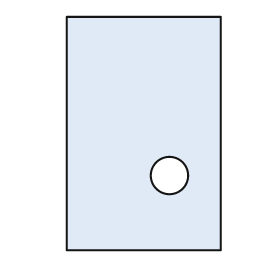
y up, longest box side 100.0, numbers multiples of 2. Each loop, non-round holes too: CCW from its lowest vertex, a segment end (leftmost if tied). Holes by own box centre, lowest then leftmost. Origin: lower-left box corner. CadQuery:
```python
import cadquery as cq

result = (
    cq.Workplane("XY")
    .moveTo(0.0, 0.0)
    .lineTo(66.0, 0.0)
    .lineTo(66.0, 100.0)
    .lineTo(0.0, 100.0)
    .close()
    .moveTo(44.0, 32.0)
    .circle(8.0)
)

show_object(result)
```